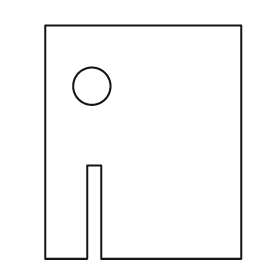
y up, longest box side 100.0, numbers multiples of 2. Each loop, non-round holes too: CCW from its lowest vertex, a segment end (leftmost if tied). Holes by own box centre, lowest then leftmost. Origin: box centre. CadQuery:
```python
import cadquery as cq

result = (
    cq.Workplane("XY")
    .moveTo(-42.0, -50.0)
    .lineTo(-24.0, -50.0)
    .lineTo(-24.0, -10.0)
    .lineTo(-18.0, -10.0)
    .lineTo(-18.0, -50.0)
    .lineTo(42.0, -50.0)
    .lineTo(42.0, 50.0)
    .lineTo(-42.0, 50.0)
    .close()
    .moveTo(-22.0, 24.0)
    .circle(8.0)
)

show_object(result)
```